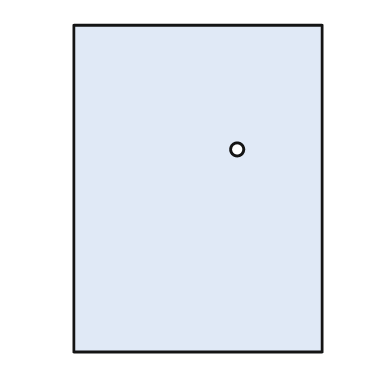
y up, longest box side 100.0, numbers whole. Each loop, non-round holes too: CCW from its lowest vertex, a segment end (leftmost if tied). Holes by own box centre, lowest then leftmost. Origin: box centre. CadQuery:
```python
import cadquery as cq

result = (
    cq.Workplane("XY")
    .moveTo(-38.0, -50.0)
    .lineTo(38.0, -50.0)
    .lineTo(38.0, 50.0)
    .lineTo(-38.0, 50.0)
    .close()
    .moveTo(12.0, 12.0)
    .circle(2.0)
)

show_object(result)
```